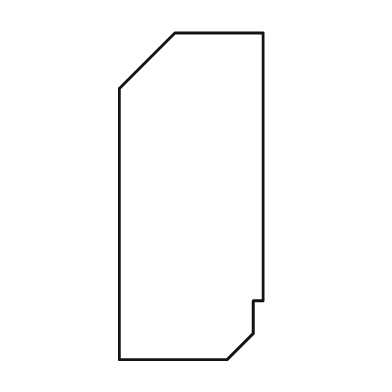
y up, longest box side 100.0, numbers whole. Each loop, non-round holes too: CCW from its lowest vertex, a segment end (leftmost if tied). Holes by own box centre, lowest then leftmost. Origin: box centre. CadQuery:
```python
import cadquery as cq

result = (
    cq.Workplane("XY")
    .moveTo(-22.0, -50.0)
    .lineTo(11.0, -50.0)
    .lineTo(19.0, -42.0)
    .lineTo(19.0, -32.0)
    .lineTo(22.0, -32.0)
    .lineTo(22.0, 50.0)
    .lineTo(-5.0, 50.0)
    .lineTo(-22.0, 33.0)
    .close()
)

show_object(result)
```